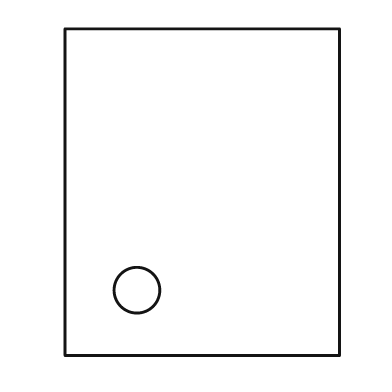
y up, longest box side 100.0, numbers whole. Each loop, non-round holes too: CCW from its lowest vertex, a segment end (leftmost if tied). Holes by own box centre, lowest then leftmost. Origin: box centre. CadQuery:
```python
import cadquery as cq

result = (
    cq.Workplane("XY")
    .moveTo(-42.0, -50.0)
    .lineTo(42.0, -50.0)
    .lineTo(42.0, 50.0)
    .lineTo(-42.0, 50.0)
    .close()
    .moveTo(-20.0, -30.0)
    .circle(7.0)
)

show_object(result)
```